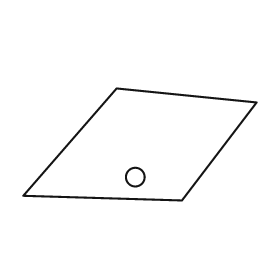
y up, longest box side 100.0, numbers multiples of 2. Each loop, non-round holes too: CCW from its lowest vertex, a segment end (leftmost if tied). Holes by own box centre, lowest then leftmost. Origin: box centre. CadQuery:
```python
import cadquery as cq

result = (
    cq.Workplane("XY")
    .moveTo(18.0, -24.0)
    .lineTo(50.0, 18.0)
    .lineTo(-10.0, 24.0)
    .lineTo(-50.0, -22.0)
    .close()
    .moveTo(-2.0, -14.0)
    .circle(4.0)
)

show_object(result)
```